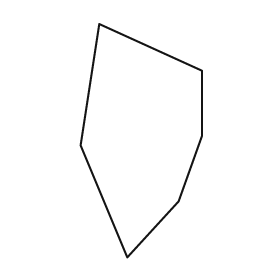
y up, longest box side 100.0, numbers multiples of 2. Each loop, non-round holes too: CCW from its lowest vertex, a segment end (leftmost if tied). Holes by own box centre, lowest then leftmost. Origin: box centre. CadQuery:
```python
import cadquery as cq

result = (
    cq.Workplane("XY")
    .moveTo(-6.0, -50.0)
    .lineTo(16.0, -26.0)
    .lineTo(26.0, 2.0)
    .lineTo(26.0, 30.0)
    .lineTo(-18.0, 50.0)
    .lineTo(-26.0, -2.0)
    .close()
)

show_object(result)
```